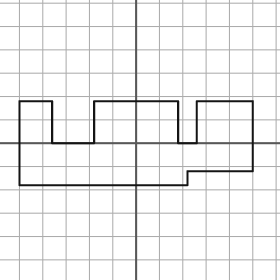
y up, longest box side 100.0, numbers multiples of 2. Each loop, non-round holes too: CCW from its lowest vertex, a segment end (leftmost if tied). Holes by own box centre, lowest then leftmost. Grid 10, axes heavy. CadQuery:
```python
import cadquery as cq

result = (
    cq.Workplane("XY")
    .moveTo(-50.0, -18.0)
    .lineTo(22.0, -18.0)
    .lineTo(22.0, -12.0)
    .lineTo(50.0, -12.0)
    .lineTo(50.0, 18.0)
    .lineTo(26.0, 18.0)
    .lineTo(26.0, 0.0)
    .lineTo(18.0, 0.0)
    .lineTo(18.0, 18.0)
    .lineTo(-18.0, 18.0)
    .lineTo(-18.0, 0.0)
    .lineTo(-36.0, 0.0)
    .lineTo(-36.0, 18.0)
    .lineTo(-50.0, 18.0)
    .close()
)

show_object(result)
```